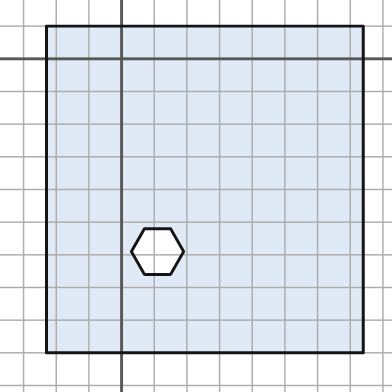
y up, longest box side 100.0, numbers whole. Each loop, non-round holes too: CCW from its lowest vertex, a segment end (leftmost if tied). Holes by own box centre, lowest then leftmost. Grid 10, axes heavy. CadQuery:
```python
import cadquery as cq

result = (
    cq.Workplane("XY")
    .moveTo(-23.0, -90.0)
    .lineTo(74.0, -90.0)
    .lineTo(74.0, 10.0)
    .lineTo(-23.0, 10.0)
    .close()
    .moveTo(7.0, -66.0)
    .lineTo(15.0, -66.0)
    .lineTo(19.0, -59.0)
    .lineTo(15.0, -52.0)
    .lineTo(7.0, -52.0)
    .lineTo(3.0, -59.0)
    .close()
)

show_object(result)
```